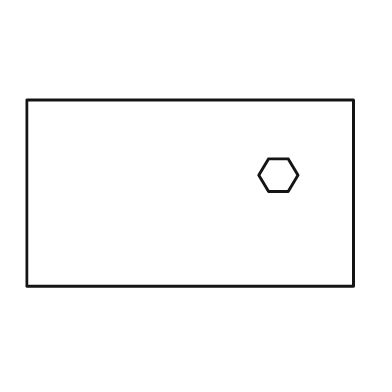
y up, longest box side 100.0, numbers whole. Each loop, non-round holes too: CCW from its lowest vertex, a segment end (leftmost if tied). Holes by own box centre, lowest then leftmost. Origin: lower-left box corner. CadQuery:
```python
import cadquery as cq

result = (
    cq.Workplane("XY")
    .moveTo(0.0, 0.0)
    .lineTo(100.0, 0.0)
    .lineTo(100.0, 57.0)
    .lineTo(0.0, 57.0)
    .close()
    .moveTo(74.0, 29.0)
    .lineTo(80.0, 29.0)
    .lineTo(83.0, 34.0)
    .lineTo(80.0, 39.0)
    .lineTo(74.0, 39.0)
    .lineTo(71.0, 34.0)
    .close()
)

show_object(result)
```